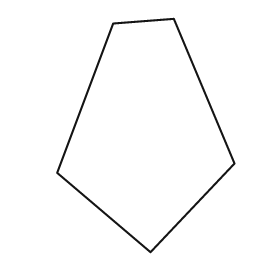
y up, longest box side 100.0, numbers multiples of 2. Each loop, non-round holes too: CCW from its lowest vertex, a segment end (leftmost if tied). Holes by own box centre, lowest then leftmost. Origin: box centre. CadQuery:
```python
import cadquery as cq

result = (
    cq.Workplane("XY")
    .moveTo(2.0, -50.0)
    .lineTo(38.0, -12.0)
    .lineTo(12.0, 50.0)
    .lineTo(-14.0, 48.0)
    .lineTo(-38.0, -16.0)
    .close()
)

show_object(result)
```